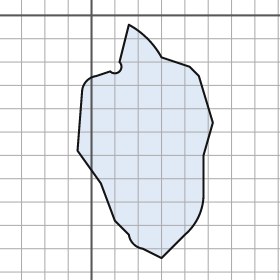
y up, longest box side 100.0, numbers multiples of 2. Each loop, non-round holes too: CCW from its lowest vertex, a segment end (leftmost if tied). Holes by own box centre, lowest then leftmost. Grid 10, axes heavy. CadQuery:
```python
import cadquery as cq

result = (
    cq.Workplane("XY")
    .moveTo(30.0, -104.0)
    .lineTo(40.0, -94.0)
    .threePointArc((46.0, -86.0), (48.0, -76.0))
    .lineTo(48.0, -60.0)
    .lineTo(52.0, -46.0)
    .lineTo(46.0, -26.0)
    .lineTo(42.0, -22.0)
    .lineTo(30.0, -18.0)
    .threePointArc((24.0, -10.0), (16.0, -4.0))
    .lineTo(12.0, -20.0)
    .threePointArc((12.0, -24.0), (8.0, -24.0))
    .lineTo(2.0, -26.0)
    .threePointArc((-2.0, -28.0), (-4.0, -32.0))
    .lineTo(-6.0, -58.0)
    .lineTo(4.0, -72.0)
    .lineTo(10.0, -88.0)
    .lineTo(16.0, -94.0)
    .threePointArc((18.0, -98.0), (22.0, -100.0))
    .close()
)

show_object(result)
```